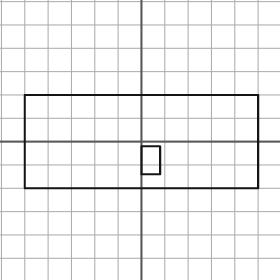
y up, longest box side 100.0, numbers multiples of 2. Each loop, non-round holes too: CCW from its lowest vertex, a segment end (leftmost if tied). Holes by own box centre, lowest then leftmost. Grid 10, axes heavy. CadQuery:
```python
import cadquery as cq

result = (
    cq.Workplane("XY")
    .moveTo(-50.0, -20.0)
    .lineTo(50.0, -20.0)
    .lineTo(50.0, 20.0)
    .lineTo(-50.0, 20.0)
    .close()
    .moveTo(0.0, -14.0)
    .lineTo(8.0, -14.0)
    .lineTo(8.0, -2.0)
    .lineTo(0.0, -2.0)
    .close()
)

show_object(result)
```